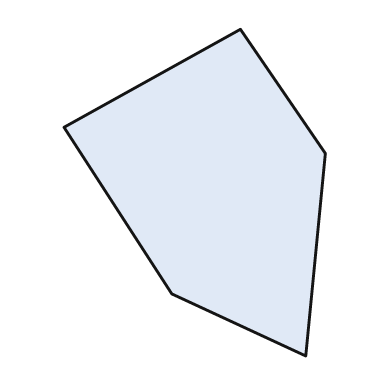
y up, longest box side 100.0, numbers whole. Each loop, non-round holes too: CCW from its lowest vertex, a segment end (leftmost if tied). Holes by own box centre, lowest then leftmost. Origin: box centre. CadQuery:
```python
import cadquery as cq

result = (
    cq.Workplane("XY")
    .moveTo(34.0, -50.0)
    .lineTo(40.0, 12.0)
    .lineTo(14.0, 50.0)
    .lineTo(-40.0, 20.0)
    .lineTo(-7.0, -31.0)
    .close()
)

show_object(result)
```